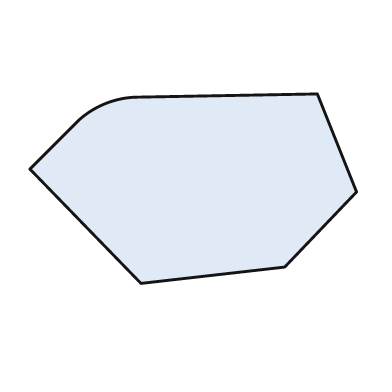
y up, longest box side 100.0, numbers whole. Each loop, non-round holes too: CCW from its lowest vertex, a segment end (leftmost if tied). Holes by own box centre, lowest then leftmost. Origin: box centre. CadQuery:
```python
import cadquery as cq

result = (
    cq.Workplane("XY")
    .moveTo(-16.0, -29.0)
    .lineTo(28.0, -24.0)
    .lineTo(50.0, -1.0)
    .lineTo(38.0, 29.0)
    .lineTo(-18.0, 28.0)
    .threePointArc((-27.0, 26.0), (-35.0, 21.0))
    .lineTo(-50.0, 6.0)
    .close()
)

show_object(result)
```